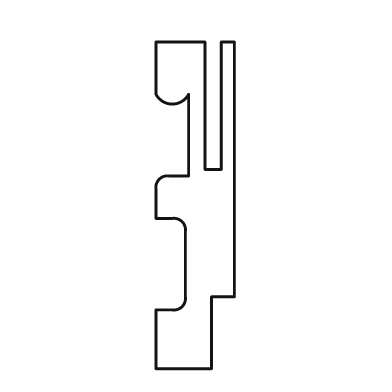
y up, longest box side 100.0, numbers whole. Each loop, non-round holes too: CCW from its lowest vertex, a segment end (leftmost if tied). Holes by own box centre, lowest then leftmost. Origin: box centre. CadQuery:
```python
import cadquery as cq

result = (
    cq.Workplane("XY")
    .moveTo(-12.0, -50.0)
    .lineTo(5.0, -50.0)
    .lineTo(5.0, -28.0)
    .lineTo(12.0, -28.0)
    .lineTo(12.0, 50.0)
    .lineTo(8.0, 50.0)
    .lineTo(8.0, 11.0)
    .lineTo(3.0, 11.0)
    .lineTo(3.0, 50.0)
    .lineTo(-12.0, 50.0)
    .lineTo(-12.0, 34.0)
    .threePointArc((-7.0, 31.0), (-2.0, 34.0))
    .lineTo(-2.0, 9.0)
    .lineTo(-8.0, 9.0)
    .threePointArc((-11.0, 8.0), (-12.0, 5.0))
    .lineTo(-12.0, -4.0)
    .lineTo(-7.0, -4.0)
    .threePointArc((-4.0, -5.0), (-3.0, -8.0))
    .lineTo(-3.0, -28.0)
    .threePointArc((-4.0, -31.0), (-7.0, -32.0))
    .lineTo(-12.0, -32.0)
    .close()
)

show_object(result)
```